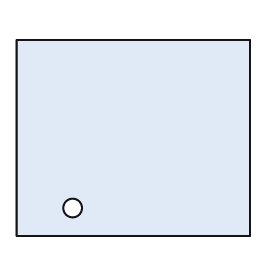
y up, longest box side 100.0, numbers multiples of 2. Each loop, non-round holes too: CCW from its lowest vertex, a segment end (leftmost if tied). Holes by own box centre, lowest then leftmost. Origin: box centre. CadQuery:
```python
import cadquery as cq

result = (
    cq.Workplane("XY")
    .moveTo(-50.0, -42.0)
    .lineTo(50.0, -42.0)
    .lineTo(50.0, 42.0)
    .lineTo(-50.0, 42.0)
    .close()
    .moveTo(-26.0, -30.0)
    .circle(4.0)
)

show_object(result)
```